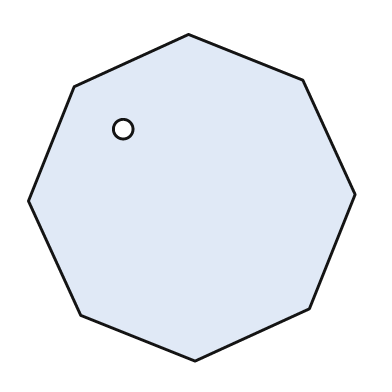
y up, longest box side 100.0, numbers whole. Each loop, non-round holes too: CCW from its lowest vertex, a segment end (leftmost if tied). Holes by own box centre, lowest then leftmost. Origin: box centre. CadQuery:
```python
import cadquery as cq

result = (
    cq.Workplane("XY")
    .moveTo(1.0, -50.0)
    .lineTo(36.0, -34.0)
    .lineTo(50.0, 1.0)
    .lineTo(34.0, 36.0)
    .lineTo(-1.0, 50.0)
    .lineTo(-36.0, 34.0)
    .lineTo(-50.0, -1.0)
    .lineTo(-34.0, -36.0)
    .close()
    .moveTo(-21.0, 21.0)
    .circle(3.0)
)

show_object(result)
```